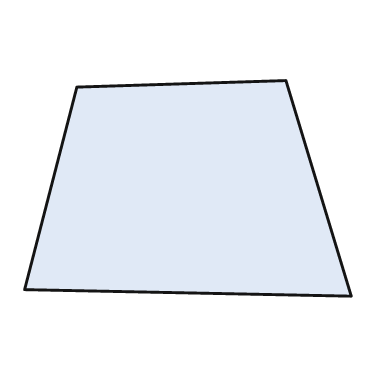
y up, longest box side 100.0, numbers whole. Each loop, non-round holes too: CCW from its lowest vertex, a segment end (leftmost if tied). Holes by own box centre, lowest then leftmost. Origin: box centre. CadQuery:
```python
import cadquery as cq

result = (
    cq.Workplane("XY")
    .moveTo(50.0, -33.0)
    .lineTo(30.0, 33.0)
    .lineTo(-34.0, 31.0)
    .lineTo(-50.0, -31.0)
    .close()
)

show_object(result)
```